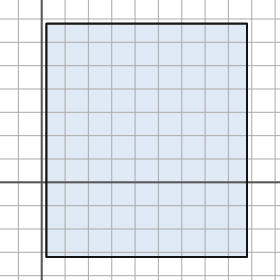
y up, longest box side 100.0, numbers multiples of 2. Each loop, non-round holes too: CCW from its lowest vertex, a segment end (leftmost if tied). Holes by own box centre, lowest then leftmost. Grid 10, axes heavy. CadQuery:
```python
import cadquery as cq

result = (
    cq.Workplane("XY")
    .moveTo(2.0, -32.0)
    .lineTo(88.0, -32.0)
    .lineTo(88.0, 68.0)
    .lineTo(2.0, 68.0)
    .close()
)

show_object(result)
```